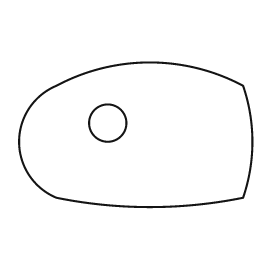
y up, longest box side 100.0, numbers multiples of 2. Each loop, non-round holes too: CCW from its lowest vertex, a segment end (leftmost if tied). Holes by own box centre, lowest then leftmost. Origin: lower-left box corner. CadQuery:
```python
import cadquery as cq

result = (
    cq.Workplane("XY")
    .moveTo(16.0, 4.0)
    .threePointArc((56.0, 0.0), (96.0, 4.0))
    .threePointArc((100.0, 28.0), (96.0, 52.0))
    .threePointArc((56.0, 62.0), (16.0, 52.0))
    .threePointArc((0.0, 28.0), (16.0, 4.0))
    .close()
    .moveTo(38.0, 36.0)
    .circle(8.0)
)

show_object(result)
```